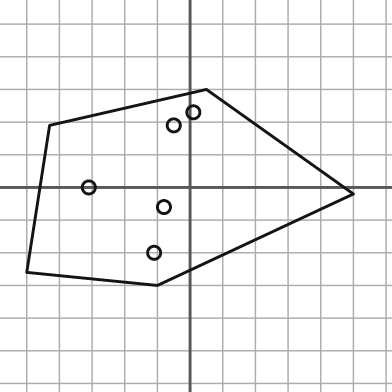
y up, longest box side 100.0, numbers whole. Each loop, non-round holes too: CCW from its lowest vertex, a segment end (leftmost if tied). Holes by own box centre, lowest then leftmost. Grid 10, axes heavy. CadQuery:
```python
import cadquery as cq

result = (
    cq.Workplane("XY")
    .moveTo(-10.0, -30.0)
    .lineTo(50.0, -2.0)
    .lineTo(5.0, 30.0)
    .lineTo(-43.0, 19.0)
    .lineTo(-50.0, -26.0)
    .close()
    .moveTo(-11.0, -20.0)
    .circle(2.0)
    .moveTo(-8.0, -6.0)
    .circle(2.0)
    .moveTo(-31.0, 0.0)
    .circle(2.0)
    .moveTo(-5.0, 19.0)
    .circle(2.0)
    .moveTo(1.0, 23.0)
    .circle(2.0)
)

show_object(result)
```